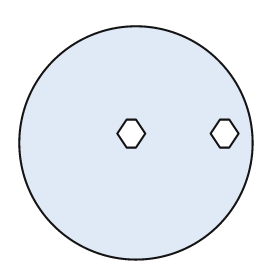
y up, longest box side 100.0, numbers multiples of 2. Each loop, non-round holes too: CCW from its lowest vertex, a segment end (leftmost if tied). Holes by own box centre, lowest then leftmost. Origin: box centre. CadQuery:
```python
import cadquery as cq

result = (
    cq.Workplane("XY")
    .moveTo(0.0, 0.0)
    .circle(50.0)
    .moveTo(-4.0, -2.0)
    .lineTo(0.0, -2.0)
    .lineTo(4.0, 4.0)
    .lineTo(0.0, 10.0)
    .lineTo(-4.0, 10.0)
    .lineTo(-8.0, 4.0)
    .close()
    .moveTo(36.0, -2.0)
    .lineTo(40.0, -2.0)
    .lineTo(44.0, 4.0)
    .lineTo(40.0, 10.0)
    .lineTo(36.0, 10.0)
    .lineTo(32.0, 4.0)
    .close()
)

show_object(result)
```